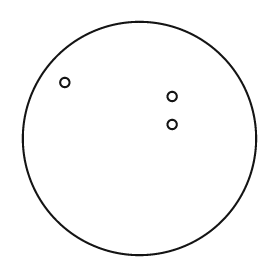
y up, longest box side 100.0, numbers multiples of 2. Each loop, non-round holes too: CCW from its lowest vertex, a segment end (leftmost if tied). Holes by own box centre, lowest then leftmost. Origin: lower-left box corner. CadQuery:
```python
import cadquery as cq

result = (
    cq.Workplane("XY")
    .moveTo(50.0, 50.0)
    .circle(50.0)
    .moveTo(64.0, 56.0)
    .circle(2.0)
    .moveTo(64.0, 68.0)
    .circle(2.0)
    .moveTo(18.0, 74.0)
    .circle(2.0)
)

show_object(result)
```